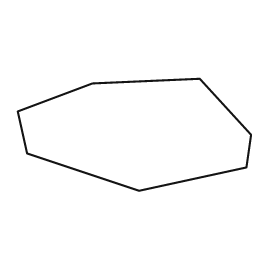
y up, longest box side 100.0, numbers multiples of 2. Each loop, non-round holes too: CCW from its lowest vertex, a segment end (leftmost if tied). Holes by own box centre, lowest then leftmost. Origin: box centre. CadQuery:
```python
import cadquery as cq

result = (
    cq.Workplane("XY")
    .moveTo(2.0, -24.0)
    .lineTo(48.0, -14.0)
    .lineTo(50.0, 0.0)
    .lineTo(28.0, 24.0)
    .lineTo(-18.0, 22.0)
    .lineTo(-50.0, 10.0)
    .lineTo(-46.0, -8.0)
    .close()
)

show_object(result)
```